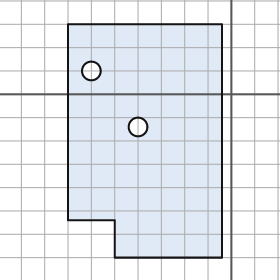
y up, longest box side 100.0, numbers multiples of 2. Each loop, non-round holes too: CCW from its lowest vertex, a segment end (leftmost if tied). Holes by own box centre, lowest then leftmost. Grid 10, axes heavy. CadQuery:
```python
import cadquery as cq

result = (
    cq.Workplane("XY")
    .moveTo(-50.0, -70.0)
    .lineTo(-4.0, -70.0)
    .lineTo(-4.0, 30.0)
    .lineTo(-70.0, 30.0)
    .lineTo(-70.0, -54.0)
    .lineTo(-50.0, -54.0)
    .close()
    .moveTo(-40.0, -14.0)
    .circle(4.0)
    .moveTo(-60.0, 10.0)
    .circle(4.0)
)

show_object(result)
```